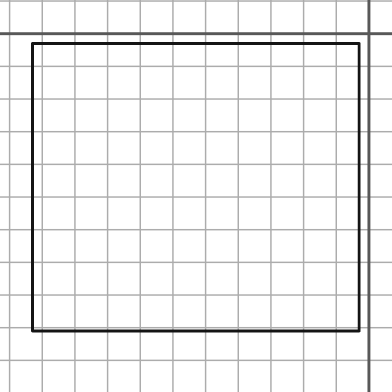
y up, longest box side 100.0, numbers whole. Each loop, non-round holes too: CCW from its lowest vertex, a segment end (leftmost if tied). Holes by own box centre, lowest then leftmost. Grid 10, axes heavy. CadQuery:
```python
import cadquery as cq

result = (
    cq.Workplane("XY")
    .moveTo(-103.0, -91.0)
    .lineTo(-3.0, -91.0)
    .lineTo(-3.0, -3.0)
    .lineTo(-103.0, -3.0)
    .close()
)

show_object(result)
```